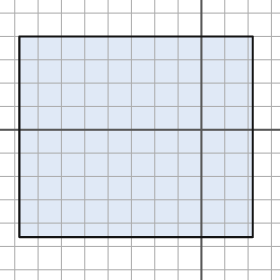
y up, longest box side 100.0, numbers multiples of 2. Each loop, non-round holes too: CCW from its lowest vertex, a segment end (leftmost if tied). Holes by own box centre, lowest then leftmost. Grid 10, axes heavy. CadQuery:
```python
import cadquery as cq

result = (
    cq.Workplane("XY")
    .moveTo(-78.0, -46.0)
    .lineTo(22.0, -46.0)
    .lineTo(22.0, 40.0)
    .lineTo(-78.0, 40.0)
    .close()
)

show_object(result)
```